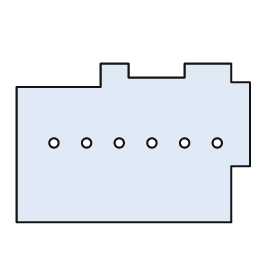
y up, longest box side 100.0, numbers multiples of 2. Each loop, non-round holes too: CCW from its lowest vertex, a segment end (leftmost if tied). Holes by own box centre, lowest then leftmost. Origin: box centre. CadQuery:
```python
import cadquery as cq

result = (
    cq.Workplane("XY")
    .moveTo(-50.0, -34.0)
    .lineTo(42.0, -34.0)
    .lineTo(42.0, -10.0)
    .lineTo(50.0, -10.0)
    .lineTo(50.0, 26.0)
    .lineTo(42.0, 26.0)
    .lineTo(42.0, 34.0)
    .lineTo(22.0, 34.0)
    .lineTo(22.0, 28.0)
    .lineTo(-2.0, 28.0)
    .lineTo(-2.0, 34.0)
    .lineTo(-14.0, 34.0)
    .lineTo(-14.0, 24.0)
    .lineTo(-50.0, 24.0)
    .close()
    .moveTo(-34.0, 0.0)
    .circle(2.0)
    .moveTo(-20.0, 0.0)
    .circle(2.0)
    .moveTo(-6.0, 0.0)
    .circle(2.0)
    .moveTo(8.0, 0.0)
    .circle(2.0)
    .moveTo(22.0, 0.0)
    .circle(2.0)
    .moveTo(36.0, 0.0)
    .circle(2.0)
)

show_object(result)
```